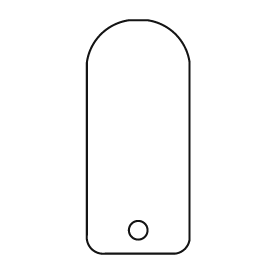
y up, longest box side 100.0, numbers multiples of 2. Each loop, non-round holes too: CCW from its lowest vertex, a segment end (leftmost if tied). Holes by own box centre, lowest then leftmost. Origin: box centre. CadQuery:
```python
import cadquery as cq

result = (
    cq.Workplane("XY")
    .moveTo(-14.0, -50.0)
    .lineTo(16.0, -50.0)
    .threePointArc((20.0, -48.0), (22.0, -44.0))
    .lineTo(22.0, 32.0)
    .threePointArc((16.0, 44.0), (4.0, 50.0))
    .lineTo(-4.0, 50.0)
    .threePointArc((-16.0, 44.0), (-22.0, 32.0))
    .lineTo(-22.0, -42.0)
    .threePointArc((-20.0, -48.0), (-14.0, -50.0))
    .close()
    .moveTo(0.0, -40.0)
    .circle(4.0)
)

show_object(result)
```